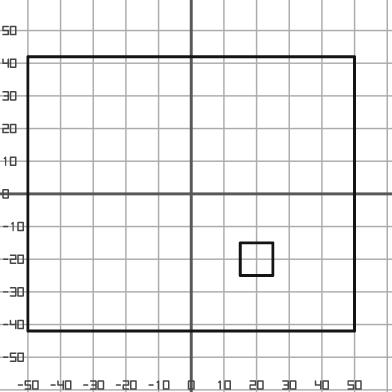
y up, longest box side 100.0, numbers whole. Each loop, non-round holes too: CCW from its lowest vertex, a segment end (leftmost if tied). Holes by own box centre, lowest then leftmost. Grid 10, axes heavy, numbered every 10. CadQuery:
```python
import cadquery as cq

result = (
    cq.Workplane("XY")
    .moveTo(-50.0, -42.0)
    .lineTo(50.0, -42.0)
    .lineTo(50.0, 42.0)
    .lineTo(-50.0, 42.0)
    .close()
    .moveTo(15.0, -25.0)
    .lineTo(25.0, -25.0)
    .lineTo(25.0, -15.0)
    .lineTo(15.0, -15.0)
    .close()
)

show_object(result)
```